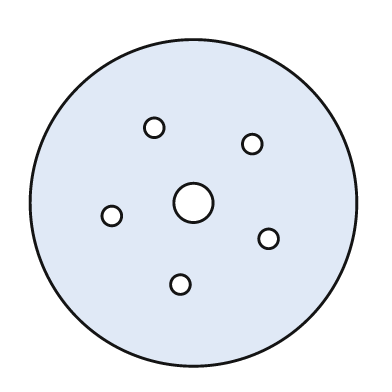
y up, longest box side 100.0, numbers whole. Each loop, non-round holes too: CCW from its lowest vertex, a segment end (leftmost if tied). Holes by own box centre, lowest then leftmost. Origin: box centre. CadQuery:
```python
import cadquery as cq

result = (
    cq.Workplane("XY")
    .moveTo(0.0, 0.0)
    .circle(50.0)
    .moveTo(-4.0, -25.0)
    .circle(3.0)
    .moveTo(23.0, -11.0)
    .circle(3.0)
    .moveTo(-25.0, -4.0)
    .circle(3.0)
    .moveTo(0.0, 0.0)
    .circle(6.0)
    .moveTo(18.0, 18.0)
    .circle(3.0)
    .moveTo(-12.0, 23.0)
    .circle(3.0)
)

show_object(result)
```